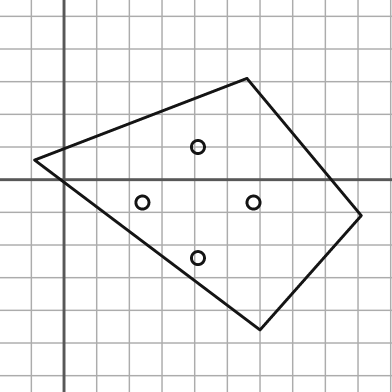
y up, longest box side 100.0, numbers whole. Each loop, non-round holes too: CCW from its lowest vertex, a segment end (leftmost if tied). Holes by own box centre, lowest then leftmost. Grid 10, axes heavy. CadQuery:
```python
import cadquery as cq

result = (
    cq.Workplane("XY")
    .moveTo(60.0, -46.0)
    .lineTo(91.0, -11.0)
    .lineTo(56.0, 31.0)
    .lineTo(-9.0, 6.0)
    .close()
    .moveTo(41.0, -24.0)
    .circle(2.0)
    .moveTo(24.0, -7.0)
    .circle(2.0)
    .moveTo(58.0, -7.0)
    .circle(2.0)
    .moveTo(41.0, 10.0)
    .circle(2.0)
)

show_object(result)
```